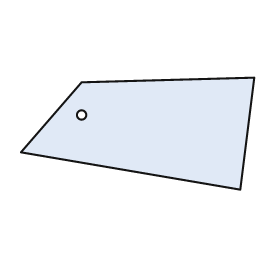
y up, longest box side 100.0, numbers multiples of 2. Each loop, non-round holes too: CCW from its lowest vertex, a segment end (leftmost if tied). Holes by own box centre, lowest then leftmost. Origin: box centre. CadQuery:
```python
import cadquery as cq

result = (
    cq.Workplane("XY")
    .moveTo(44.0, -24.0)
    .lineTo(50.0, 24.0)
    .lineTo(-24.0, 22.0)
    .lineTo(-50.0, -8.0)
    .close()
    .moveTo(-24.0, 8.0)
    .circle(2.0)
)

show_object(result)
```